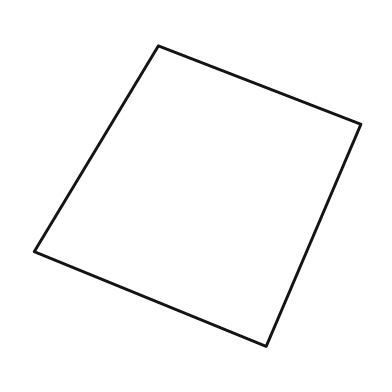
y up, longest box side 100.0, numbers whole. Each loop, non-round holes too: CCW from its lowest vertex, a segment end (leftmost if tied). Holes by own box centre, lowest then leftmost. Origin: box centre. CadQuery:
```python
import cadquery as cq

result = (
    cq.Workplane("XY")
    .moveTo(21.0, -46.0)
    .lineTo(50.0, 22.0)
    .lineTo(-12.0, 46.0)
    .lineTo(-50.0, -17.0)
    .close()
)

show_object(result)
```